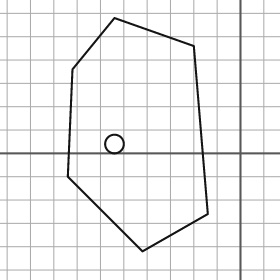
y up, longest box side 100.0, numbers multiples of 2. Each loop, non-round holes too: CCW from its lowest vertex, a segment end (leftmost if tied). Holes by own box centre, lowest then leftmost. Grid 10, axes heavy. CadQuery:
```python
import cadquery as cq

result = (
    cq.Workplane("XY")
    .moveTo(-42.0, -42.0)
    .lineTo(-14.0, -26.0)
    .lineTo(-20.0, 46.0)
    .lineTo(-54.0, 58.0)
    .lineTo(-72.0, 36.0)
    .lineTo(-74.0, -10.0)
    .close()
    .moveTo(-54.0, 4.0)
    .circle(4.0)
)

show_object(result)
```